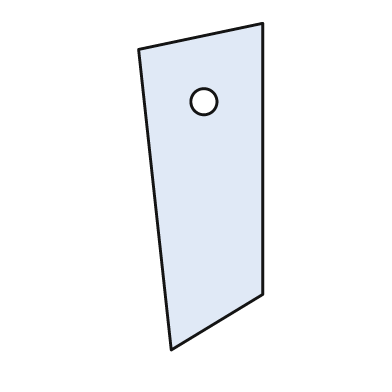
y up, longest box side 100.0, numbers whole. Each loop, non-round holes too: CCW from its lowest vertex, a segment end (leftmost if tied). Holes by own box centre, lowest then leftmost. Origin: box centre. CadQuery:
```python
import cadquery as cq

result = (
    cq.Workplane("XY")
    .moveTo(-9.0, -50.0)
    .lineTo(19.0, -33.0)
    .lineTo(19.0, 50.0)
    .lineTo(-19.0, 42.0)
    .close()
    .moveTo(1.0, 26.0)
    .circle(4.0)
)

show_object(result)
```